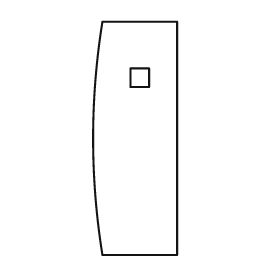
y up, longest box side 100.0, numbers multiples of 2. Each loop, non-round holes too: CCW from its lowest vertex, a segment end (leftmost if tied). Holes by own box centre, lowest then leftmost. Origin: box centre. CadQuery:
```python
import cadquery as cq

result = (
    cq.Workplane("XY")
    .moveTo(-14.0, -50.0)
    .lineTo(18.0, -50.0)
    .lineTo(18.0, 50.0)
    .lineTo(-14.0, 50.0)
    .threePointArc((-18.0, 0.0), (-14.0, -50.0))
    .close()
    .moveTo(-2.0, 22.0)
    .lineTo(6.0, 22.0)
    .lineTo(6.0, 30.0)
    .lineTo(-2.0, 30.0)
    .close()
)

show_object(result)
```